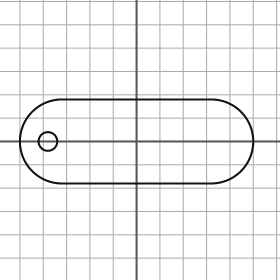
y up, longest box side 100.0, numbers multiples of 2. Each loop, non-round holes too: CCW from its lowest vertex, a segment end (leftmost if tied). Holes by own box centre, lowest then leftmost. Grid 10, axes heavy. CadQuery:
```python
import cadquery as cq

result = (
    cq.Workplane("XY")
    .moveTo(-32.0, -18.0)
    .lineTo(32.0, -18.0)
    .threePointArc((50.0, 0.0), (32.0, 18.0))
    .lineTo(-32.0, 18.0)
    .threePointArc((-50.0, 0.0), (-32.0, -18.0))
    .close()
    .moveTo(-38.0, 0.0)
    .circle(4.0)
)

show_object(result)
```